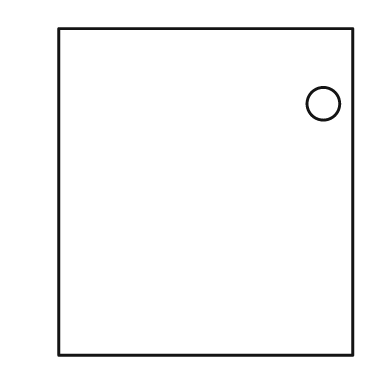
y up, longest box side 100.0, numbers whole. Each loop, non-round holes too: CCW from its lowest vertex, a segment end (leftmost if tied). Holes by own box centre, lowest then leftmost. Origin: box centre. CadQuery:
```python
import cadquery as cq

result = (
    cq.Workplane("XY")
    .moveTo(-45.0, -50.0)
    .lineTo(45.0, -50.0)
    .lineTo(45.0, 50.0)
    .lineTo(-45.0, 50.0)
    .close()
    .moveTo(36.0, 27.0)
    .circle(5.0)
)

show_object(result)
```